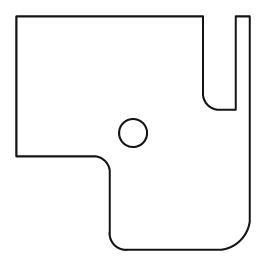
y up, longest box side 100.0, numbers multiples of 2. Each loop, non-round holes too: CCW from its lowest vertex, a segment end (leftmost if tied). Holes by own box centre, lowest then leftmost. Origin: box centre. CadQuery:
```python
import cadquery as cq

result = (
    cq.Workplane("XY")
    .moveTo(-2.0, -50.0)
    .lineTo(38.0, -50.0)
    .threePointArc((46.0, -46.0), (50.0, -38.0))
    .lineTo(50.0, 50.0)
    .lineTo(44.0, 50.0)
    .lineTo(44.0, 10.0)
    .lineTo(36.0, 10.0)
    .threePointArc((32.0, 12.0), (30.0, 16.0))
    .lineTo(30.0, 50.0)
    .lineTo(-50.0, 50.0)
    .lineTo(-50.0, -10.0)
    .lineTo(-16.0, -10.0)
    .threePointArc((-12.0, -12.0), (-10.0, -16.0))
    .lineTo(-10.0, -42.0)
    .threePointArc((-8.0, -48.0), (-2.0, -50.0))
    .close()
    .moveTo(0.0, 0.0)
    .circle(6.0)
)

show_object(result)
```